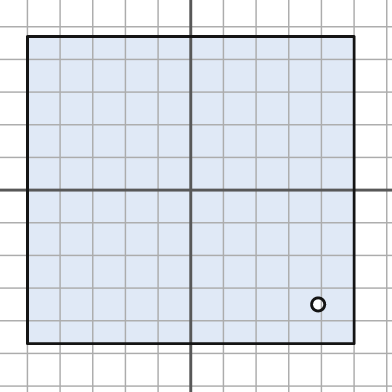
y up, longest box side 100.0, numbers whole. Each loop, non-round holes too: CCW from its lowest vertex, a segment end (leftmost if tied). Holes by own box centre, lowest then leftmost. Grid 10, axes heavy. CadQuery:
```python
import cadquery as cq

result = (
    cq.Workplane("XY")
    .moveTo(-50.0, -47.0)
    .lineTo(50.0, -47.0)
    .lineTo(50.0, 47.0)
    .lineTo(-50.0, 47.0)
    .close()
    .moveTo(39.0, -35.0)
    .circle(2.0)
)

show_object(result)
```